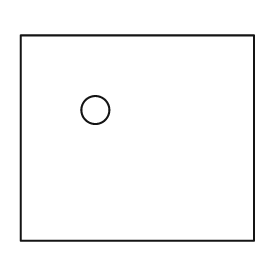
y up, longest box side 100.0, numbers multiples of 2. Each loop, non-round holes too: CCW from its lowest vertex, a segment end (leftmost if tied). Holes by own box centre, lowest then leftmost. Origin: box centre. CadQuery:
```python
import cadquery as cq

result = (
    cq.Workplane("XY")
    .moveTo(-50.0, -44.0)
    .lineTo(50.0, -44.0)
    .lineTo(50.0, 44.0)
    .lineTo(-50.0, 44.0)
    .close()
    .moveTo(-18.0, 12.0)
    .circle(6.0)
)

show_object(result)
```